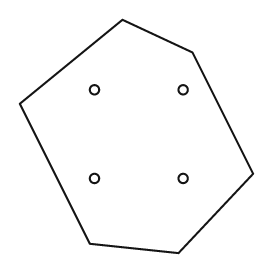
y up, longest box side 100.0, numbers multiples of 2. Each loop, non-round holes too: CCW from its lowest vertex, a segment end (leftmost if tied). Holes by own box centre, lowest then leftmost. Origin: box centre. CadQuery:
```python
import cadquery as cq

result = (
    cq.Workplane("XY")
    .moveTo(18.0, -50.0)
    .lineTo(50.0, -16.0)
    .lineTo(24.0, 36.0)
    .lineTo(-6.0, 50.0)
    .lineTo(-50.0, 14.0)
    .lineTo(-20.0, -46.0)
    .close()
    .moveTo(-18.0, -18.0)
    .circle(2.0)
    .moveTo(20.0, -18.0)
    .circle(2.0)
    .moveTo(-18.0, 20.0)
    .circle(2.0)
    .moveTo(20.0, 20.0)
    .circle(2.0)
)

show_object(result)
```